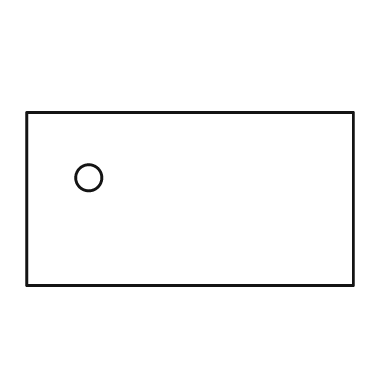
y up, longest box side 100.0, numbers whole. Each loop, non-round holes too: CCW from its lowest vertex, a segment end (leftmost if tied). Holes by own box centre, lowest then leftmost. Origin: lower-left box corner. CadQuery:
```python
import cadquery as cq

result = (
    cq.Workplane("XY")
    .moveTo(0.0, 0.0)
    .lineTo(100.0, 0.0)
    .lineTo(100.0, 53.0)
    .lineTo(0.0, 53.0)
    .close()
    .moveTo(19.0, 33.0)
    .circle(4.0)
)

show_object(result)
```